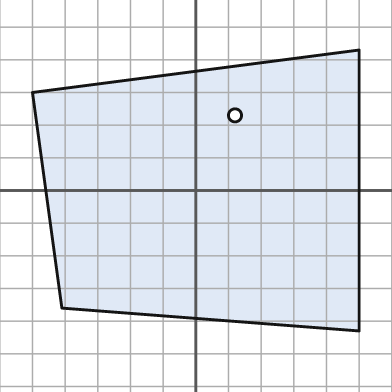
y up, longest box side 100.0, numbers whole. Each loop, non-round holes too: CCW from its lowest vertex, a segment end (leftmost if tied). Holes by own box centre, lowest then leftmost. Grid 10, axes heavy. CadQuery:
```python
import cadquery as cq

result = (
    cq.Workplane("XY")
    .moveTo(50.0, -43.0)
    .lineTo(50.0, 43.0)
    .lineTo(-50.0, 30.0)
    .lineTo(-41.0, -36.0)
    .close()
    .moveTo(12.0, 23.0)
    .circle(2.0)
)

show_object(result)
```